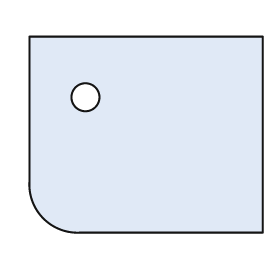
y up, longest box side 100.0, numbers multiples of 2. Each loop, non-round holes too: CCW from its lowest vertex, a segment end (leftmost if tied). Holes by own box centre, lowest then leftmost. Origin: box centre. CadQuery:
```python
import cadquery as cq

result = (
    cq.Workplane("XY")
    .moveTo(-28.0, -42.0)
    .lineTo(50.0, -42.0)
    .lineTo(50.0, 42.0)
    .lineTo(-50.0, 42.0)
    .lineTo(-50.0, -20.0)
    .threePointArc((-44.0, -36.0), (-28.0, -42.0))
    .close()
    .moveTo(-26.0, 16.0)
    .circle(6.0)
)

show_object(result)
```